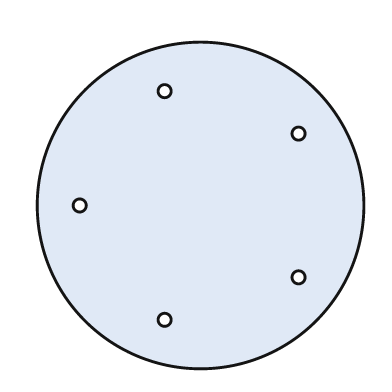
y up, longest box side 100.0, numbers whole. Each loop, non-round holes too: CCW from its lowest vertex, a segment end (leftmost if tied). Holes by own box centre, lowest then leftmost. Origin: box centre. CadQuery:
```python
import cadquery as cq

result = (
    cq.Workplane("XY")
    .moveTo(0.0, 0.0)
    .circle(50.0)
    .moveTo(-11.0, -35.0)
    .circle(2.0)
    .moveTo(30.0, -22.0)
    .circle(2.0)
    .moveTo(-37.0, 0.0)
    .circle(2.0)
    .moveTo(30.0, 22.0)
    .circle(2.0)
    .moveTo(-11.0, 35.0)
    .circle(2.0)
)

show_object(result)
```